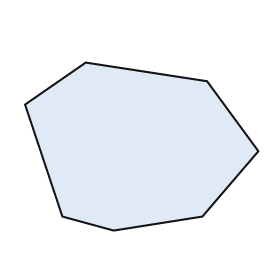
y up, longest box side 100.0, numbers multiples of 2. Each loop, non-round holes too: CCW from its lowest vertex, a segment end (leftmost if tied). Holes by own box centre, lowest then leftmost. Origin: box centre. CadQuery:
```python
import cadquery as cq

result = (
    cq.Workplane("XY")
    .moveTo(-12.0, -36.0)
    .lineTo(26.0, -30.0)
    .lineTo(50.0, -2.0)
    .lineTo(28.0, 28.0)
    .lineTo(-24.0, 36.0)
    .lineTo(-50.0, 18.0)
    .lineTo(-34.0, -30.0)
    .close()
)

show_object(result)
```